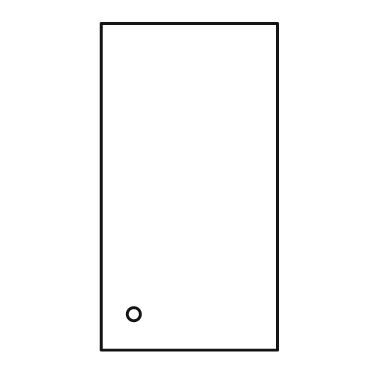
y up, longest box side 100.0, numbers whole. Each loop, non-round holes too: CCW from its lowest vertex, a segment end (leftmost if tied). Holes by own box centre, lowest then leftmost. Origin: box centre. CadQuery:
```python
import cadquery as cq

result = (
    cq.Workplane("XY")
    .moveTo(-27.0, -50.0)
    .lineTo(27.0, -50.0)
    .lineTo(27.0, 50.0)
    .lineTo(-27.0, 50.0)
    .close()
    .moveTo(-17.0, -39.0)
    .circle(2.0)
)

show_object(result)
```